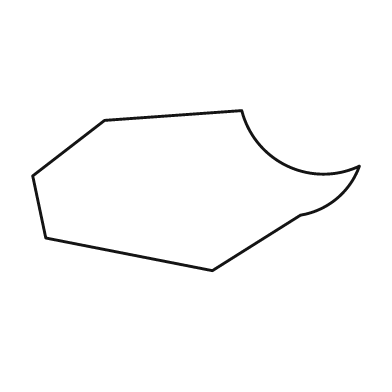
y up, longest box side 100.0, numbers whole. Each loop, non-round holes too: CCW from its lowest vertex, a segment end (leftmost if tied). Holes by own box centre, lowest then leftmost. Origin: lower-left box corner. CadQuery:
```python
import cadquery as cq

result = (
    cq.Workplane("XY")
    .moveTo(55.0, 0.0)
    .lineTo(82.0, 17.0)
    .threePointArc((93.0, 22.0), (100.0, 32.0))
    .threePointArc((78.0, 32.0), (64.0, 49.0))
    .lineTo(22.0, 46.0)
    .lineTo(0.0, 29.0)
    .lineTo(4.0, 10.0)
    .close()
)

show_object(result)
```